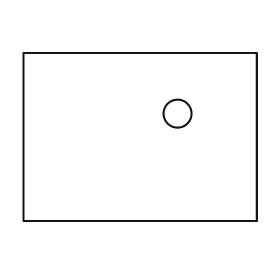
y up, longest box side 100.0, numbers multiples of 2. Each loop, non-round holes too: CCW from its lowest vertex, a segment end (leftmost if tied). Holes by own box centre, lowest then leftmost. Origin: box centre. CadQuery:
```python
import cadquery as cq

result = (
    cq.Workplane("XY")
    .moveTo(-50.0, -36.0)
    .lineTo(50.0, -36.0)
    .lineTo(50.0, 36.0)
    .lineTo(-50.0, 36.0)
    .close()
    .moveTo(16.0, 10.0)
    .circle(6.0)
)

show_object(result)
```